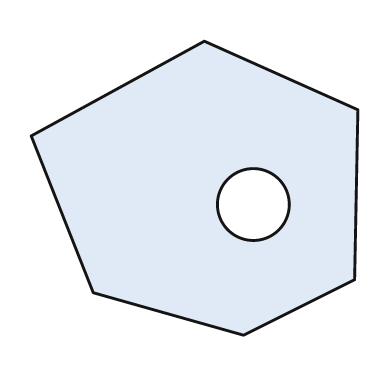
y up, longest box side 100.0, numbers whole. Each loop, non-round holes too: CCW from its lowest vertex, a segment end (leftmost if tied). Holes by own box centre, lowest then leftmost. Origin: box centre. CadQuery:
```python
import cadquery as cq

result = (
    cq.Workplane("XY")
    .moveTo(15.0, -45.0)
    .lineTo(49.0, -28.0)
    .lineTo(50.0, 24.0)
    .lineTo(3.0, 45.0)
    .lineTo(-50.0, 16.0)
    .lineTo(-31.0, -32.0)
    .close()
    .moveTo(18.0, -5.0)
    .circle(11.0)
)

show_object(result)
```